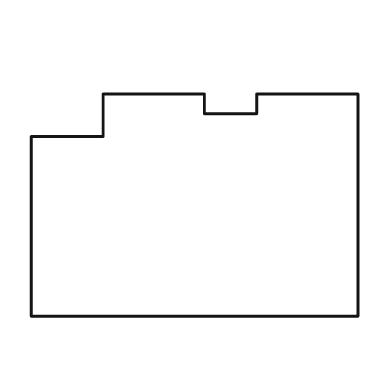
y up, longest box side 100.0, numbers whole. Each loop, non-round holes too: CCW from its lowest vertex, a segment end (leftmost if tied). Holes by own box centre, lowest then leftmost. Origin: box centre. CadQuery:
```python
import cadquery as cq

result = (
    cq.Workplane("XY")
    .moveTo(-50.0, -34.0)
    .lineTo(50.0, -34.0)
    .lineTo(50.0, 34.0)
    .lineTo(19.0, 34.0)
    .lineTo(19.0, 28.0)
    .lineTo(3.0, 28.0)
    .lineTo(3.0, 34.0)
    .lineTo(-28.0, 34.0)
    .lineTo(-28.0, 21.0)
    .lineTo(-50.0, 21.0)
    .close()
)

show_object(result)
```